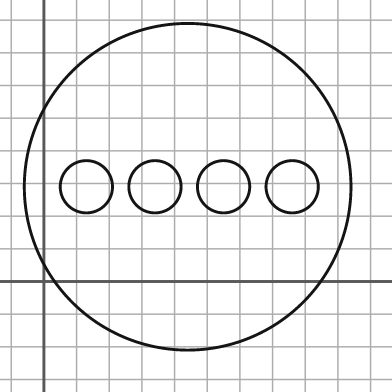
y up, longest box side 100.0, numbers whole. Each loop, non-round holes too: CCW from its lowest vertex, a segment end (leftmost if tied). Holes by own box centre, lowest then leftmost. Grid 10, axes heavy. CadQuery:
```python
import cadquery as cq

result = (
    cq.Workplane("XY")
    .moveTo(44.0, 29.0)
    .circle(50.0)
    .moveTo(13.0, 29.0)
    .circle(8.0)
    .moveTo(34.0, 29.0)
    .circle(8.0)
    .moveTo(55.0, 29.0)
    .circle(8.0)
    .moveTo(76.0, 29.0)
    .circle(8.0)
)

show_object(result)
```